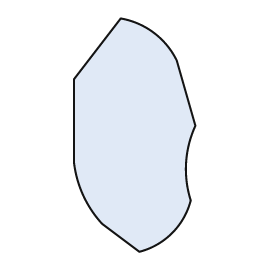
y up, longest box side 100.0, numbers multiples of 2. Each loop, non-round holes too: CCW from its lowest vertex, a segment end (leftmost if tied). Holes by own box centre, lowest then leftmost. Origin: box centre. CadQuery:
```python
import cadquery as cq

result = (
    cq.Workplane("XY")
    .moveTo(2.0, -50.0)
    .threePointArc((16.0, -42.0), (24.0, -28.0))
    .threePointArc((22.0, -12.0), (26.0, 4.0))
    .lineTo(18.0, 32.0)
    .threePointArc((8.0, 44.0), (-6.0, 50.0))
    .lineTo(-26.0, 24.0)
    .lineTo(-26.0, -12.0)
    .threePointArc((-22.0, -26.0), (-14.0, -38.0))
    .close()
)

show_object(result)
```